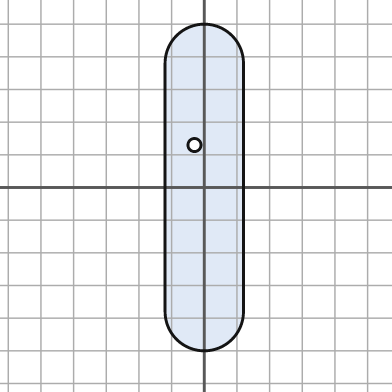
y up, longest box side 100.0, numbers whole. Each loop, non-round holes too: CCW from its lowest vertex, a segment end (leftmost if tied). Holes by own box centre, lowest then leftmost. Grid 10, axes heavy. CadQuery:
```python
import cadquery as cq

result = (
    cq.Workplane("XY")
    .moveTo(-12.0, -38.0)
    .threePointArc((0.0, -50.0), (12.0, -38.0))
    .lineTo(12.0, 38.0)
    .threePointArc((0.0, 50.0), (-12.0, 38.0))
    .close()
    .moveTo(-3.0, 13.0)
    .circle(2.0)
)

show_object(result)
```